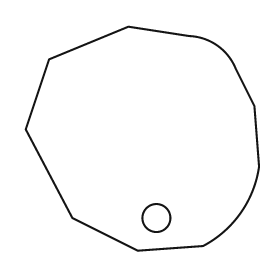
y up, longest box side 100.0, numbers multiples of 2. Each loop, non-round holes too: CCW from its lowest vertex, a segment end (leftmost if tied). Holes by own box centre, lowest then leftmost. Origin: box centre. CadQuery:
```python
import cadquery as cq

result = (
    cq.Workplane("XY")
    .moveTo(-2.0, -48.0)
    .lineTo(26.0, -46.0)
    .threePointArc((42.0, -32.0), (50.0, -12.0))
    .lineTo(48.0, 14.0)
    .lineTo(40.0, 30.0)
    .threePointArc((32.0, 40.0), (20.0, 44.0))
    .lineTo(-6.0, 48.0)
    .lineTo(-40.0, 34.0)
    .lineTo(-50.0, 4.0)
    .lineTo(-30.0, -34.0)
    .close()
    .moveTo(6.0, -34.0)
    .circle(6.0)
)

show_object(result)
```